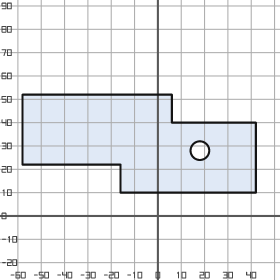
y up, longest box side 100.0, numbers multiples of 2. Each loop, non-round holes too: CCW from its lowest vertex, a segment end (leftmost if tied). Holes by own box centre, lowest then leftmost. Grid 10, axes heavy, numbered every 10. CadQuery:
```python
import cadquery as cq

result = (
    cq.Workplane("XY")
    .moveTo(-16.0, 10.0)
    .lineTo(42.0, 10.0)
    .lineTo(42.0, 40.0)
    .lineTo(6.0, 40.0)
    .lineTo(6.0, 52.0)
    .lineTo(-58.0, 52.0)
    .lineTo(-58.0, 22.0)
    .lineTo(-16.0, 22.0)
    .close()
    .moveTo(18.0, 28.0)
    .circle(4.0)
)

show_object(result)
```